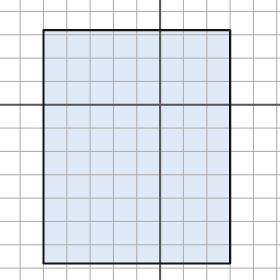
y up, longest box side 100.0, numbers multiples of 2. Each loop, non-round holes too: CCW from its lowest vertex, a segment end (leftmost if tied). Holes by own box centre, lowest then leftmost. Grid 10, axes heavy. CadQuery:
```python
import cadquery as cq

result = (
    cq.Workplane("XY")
    .moveTo(-50.0, -68.0)
    .lineTo(30.0, -68.0)
    .lineTo(30.0, 32.0)
    .lineTo(-50.0, 32.0)
    .close()
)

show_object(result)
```